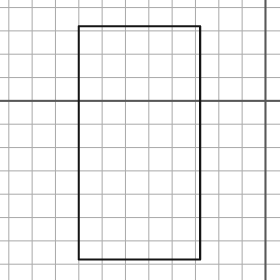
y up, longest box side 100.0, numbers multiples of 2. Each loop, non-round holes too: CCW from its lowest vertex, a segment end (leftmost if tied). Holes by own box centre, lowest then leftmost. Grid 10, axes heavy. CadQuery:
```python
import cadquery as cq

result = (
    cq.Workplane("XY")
    .moveTo(-80.0, -68.0)
    .lineTo(-28.0, -68.0)
    .lineTo(-28.0, 32.0)
    .lineTo(-80.0, 32.0)
    .close()
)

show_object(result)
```